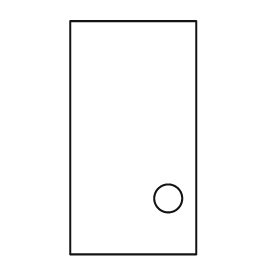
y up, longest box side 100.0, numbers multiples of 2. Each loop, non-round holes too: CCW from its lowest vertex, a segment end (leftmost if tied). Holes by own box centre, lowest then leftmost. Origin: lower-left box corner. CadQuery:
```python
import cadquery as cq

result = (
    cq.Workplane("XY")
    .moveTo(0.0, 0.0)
    .lineTo(54.0, 0.0)
    .lineTo(54.0, 100.0)
    .lineTo(0.0, 100.0)
    .close()
    .moveTo(42.0, 24.0)
    .circle(6.0)
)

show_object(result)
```